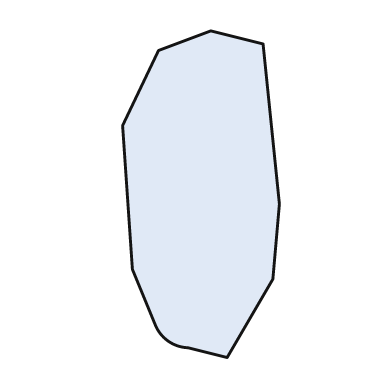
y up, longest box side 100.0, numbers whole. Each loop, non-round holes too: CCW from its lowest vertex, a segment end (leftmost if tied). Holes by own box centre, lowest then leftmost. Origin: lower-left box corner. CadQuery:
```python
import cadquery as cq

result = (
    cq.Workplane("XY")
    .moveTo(32.0, 0.0)
    .lineTo(46.0, 24.0)
    .lineTo(48.0, 47.0)
    .lineTo(43.0, 96.0)
    .lineTo(27.0, 100.0)
    .lineTo(11.0, 94.0)
    .lineTo(0.0, 71.0)
    .lineTo(3.0, 27.0)
    .lineTo(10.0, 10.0)
    .threePointArc((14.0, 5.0), (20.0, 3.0))
    .close()
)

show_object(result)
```